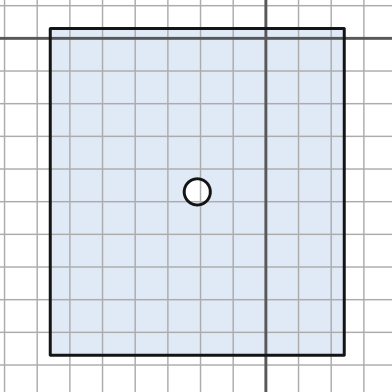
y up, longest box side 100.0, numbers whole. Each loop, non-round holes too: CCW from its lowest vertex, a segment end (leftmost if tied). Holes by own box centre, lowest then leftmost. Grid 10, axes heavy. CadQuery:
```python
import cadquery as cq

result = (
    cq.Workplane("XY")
    .moveTo(-66.0, -97.0)
    .lineTo(24.0, -97.0)
    .lineTo(24.0, 3.0)
    .lineTo(-66.0, 3.0)
    .close()
    .moveTo(-21.0, -47.0)
    .circle(4.0)
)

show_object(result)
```